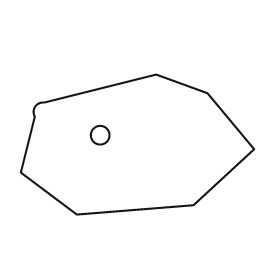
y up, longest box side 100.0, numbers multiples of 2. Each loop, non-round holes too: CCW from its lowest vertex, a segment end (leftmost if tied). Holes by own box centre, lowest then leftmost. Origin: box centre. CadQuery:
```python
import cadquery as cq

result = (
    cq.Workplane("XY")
    .moveTo(-26.0, -30.0)
    .lineTo(24.0, -26.0)
    .lineTo(50.0, -2.0)
    .lineTo(30.0, 22.0)
    .lineTo(8.0, 30.0)
    .lineTo(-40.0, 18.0)
    .threePointArc((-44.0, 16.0), (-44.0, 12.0))
    .lineTo(-50.0, -12.0)
    .close()
    .moveTo(-16.0, 4.0)
    .circle(4.0)
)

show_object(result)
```